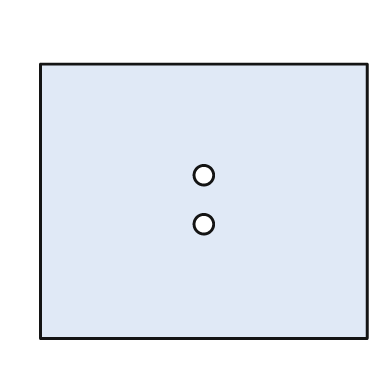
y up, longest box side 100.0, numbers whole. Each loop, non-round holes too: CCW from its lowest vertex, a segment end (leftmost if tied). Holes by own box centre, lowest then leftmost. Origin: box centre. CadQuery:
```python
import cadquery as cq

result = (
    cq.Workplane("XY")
    .moveTo(-50.0, -42.0)
    .lineTo(50.0, -42.0)
    .lineTo(50.0, 42.0)
    .lineTo(-50.0, 42.0)
    .close()
    .moveTo(0.0, -7.0)
    .circle(3.0)
    .moveTo(0.0, 8.0)
    .circle(3.0)
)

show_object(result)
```